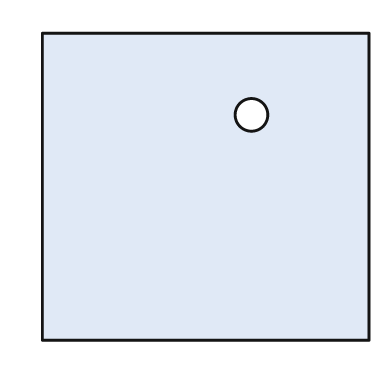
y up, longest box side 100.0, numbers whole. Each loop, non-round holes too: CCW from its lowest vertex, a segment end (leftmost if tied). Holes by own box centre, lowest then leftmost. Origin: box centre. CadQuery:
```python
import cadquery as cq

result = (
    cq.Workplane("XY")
    .moveTo(-50.0, -47.0)
    .lineTo(50.0, -47.0)
    .lineTo(50.0, 47.0)
    .lineTo(-50.0, 47.0)
    .close()
    .moveTo(14.0, 22.0)
    .circle(5.0)
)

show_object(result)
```